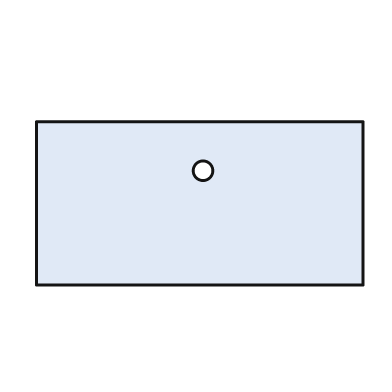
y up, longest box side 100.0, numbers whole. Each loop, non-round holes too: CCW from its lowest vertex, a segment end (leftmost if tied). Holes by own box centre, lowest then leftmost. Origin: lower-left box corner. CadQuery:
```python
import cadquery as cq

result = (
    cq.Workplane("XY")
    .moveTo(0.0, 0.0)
    .lineTo(100.0, 0.0)
    .lineTo(100.0, 50.0)
    .lineTo(0.0, 50.0)
    .close()
    .moveTo(51.0, 35.0)
    .circle(3.0)
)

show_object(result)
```